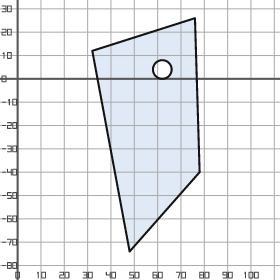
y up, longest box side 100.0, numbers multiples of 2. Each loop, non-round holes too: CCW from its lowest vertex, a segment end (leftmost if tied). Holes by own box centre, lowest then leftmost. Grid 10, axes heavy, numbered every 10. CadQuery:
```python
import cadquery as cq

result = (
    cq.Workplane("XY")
    .moveTo(48.0, -74.0)
    .lineTo(78.0, -40.0)
    .lineTo(76.0, 26.0)
    .lineTo(32.0, 12.0)
    .close()
    .moveTo(62.0, 4.0)
    .circle(4.0)
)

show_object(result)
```